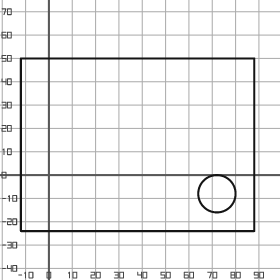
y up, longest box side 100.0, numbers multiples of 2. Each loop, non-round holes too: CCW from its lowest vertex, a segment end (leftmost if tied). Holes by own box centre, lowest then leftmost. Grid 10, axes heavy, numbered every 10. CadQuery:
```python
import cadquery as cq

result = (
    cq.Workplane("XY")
    .moveTo(-12.0, -24.0)
    .lineTo(88.0, -24.0)
    .lineTo(88.0, 50.0)
    .lineTo(-12.0, 50.0)
    .close()
    .moveTo(72.0, -8.0)
    .circle(8.0)
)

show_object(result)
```